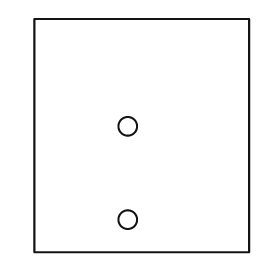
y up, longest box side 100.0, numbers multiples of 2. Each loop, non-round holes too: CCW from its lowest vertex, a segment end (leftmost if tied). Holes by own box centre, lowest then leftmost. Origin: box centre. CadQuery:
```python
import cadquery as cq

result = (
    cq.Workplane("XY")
    .moveTo(-46.0, -50.0)
    .lineTo(46.0, -50.0)
    .lineTo(46.0, 50.0)
    .lineTo(-46.0, 50.0)
    .close()
    .moveTo(-6.0, -36.0)
    .circle(4.0)
    .moveTo(-6.0, 4.0)
    .circle(4.0)
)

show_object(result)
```